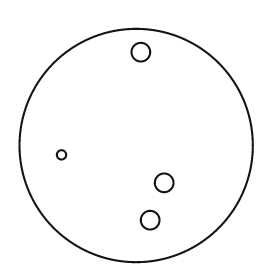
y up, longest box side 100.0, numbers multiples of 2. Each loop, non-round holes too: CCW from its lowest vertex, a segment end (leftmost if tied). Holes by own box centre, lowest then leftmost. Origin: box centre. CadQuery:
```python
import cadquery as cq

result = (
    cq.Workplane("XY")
    .moveTo(0.0, 0.0)
    .circle(50.0)
    .moveTo(6.0, -32.0)
    .circle(4.0)
    .moveTo(12.0, -16.0)
    .circle(4.0)
    .moveTo(-32.0, -4.0)
    .circle(2.0)
    .moveTo(2.0, 40.0)
    .circle(4.0)
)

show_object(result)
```